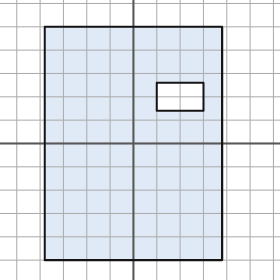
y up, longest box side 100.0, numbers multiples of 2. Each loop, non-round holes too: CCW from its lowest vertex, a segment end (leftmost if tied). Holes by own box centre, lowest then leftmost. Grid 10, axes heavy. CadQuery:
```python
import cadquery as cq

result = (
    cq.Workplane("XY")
    .moveTo(-38.0, -50.0)
    .lineTo(38.0, -50.0)
    .lineTo(38.0, 50.0)
    .lineTo(-38.0, 50.0)
    .close()
    .moveTo(10.0, 14.0)
    .lineTo(30.0, 14.0)
    .lineTo(30.0, 26.0)
    .lineTo(10.0, 26.0)
    .close()
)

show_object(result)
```